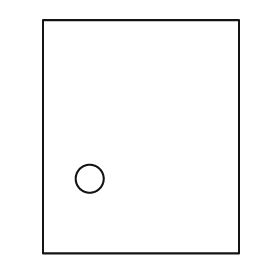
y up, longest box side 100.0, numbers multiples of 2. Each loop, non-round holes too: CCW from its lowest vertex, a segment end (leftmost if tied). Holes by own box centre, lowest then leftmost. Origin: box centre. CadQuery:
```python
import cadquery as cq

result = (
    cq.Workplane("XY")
    .moveTo(-42.0, -50.0)
    .lineTo(42.0, -50.0)
    .lineTo(42.0, 50.0)
    .lineTo(-42.0, 50.0)
    .close()
    .moveTo(-22.0, -18.0)
    .circle(6.0)
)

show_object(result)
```